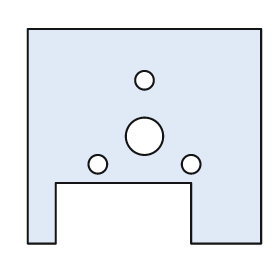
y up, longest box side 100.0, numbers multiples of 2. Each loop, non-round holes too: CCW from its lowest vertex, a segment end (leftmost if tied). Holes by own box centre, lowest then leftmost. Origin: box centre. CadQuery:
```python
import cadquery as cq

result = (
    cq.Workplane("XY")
    .moveTo(-50.0, -46.0)
    .lineTo(-38.0, -46.0)
    .lineTo(-38.0, -20.0)
    .lineTo(20.0, -20.0)
    .lineTo(20.0, -46.0)
    .lineTo(50.0, -46.0)
    .lineTo(50.0, 46.0)
    .lineTo(-50.0, 46.0)
    .close()
    .moveTo(-20.0, -12.0)
    .circle(4.0)
    .moveTo(20.0, -12.0)
    .circle(4.0)
    .moveTo(0.0, 0.0)
    .circle(8.0)
    .moveTo(0.0, 24.0)
    .circle(4.0)
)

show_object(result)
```